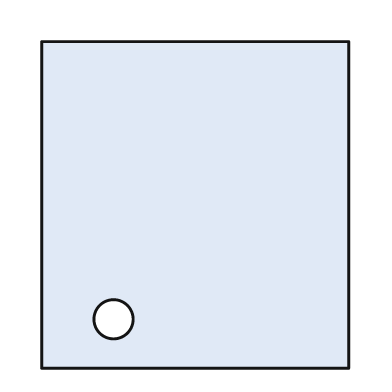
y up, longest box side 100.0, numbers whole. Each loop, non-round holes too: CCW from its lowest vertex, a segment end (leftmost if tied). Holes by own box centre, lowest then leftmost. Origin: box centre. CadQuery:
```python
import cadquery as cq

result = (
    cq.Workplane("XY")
    .moveTo(-47.0, -50.0)
    .lineTo(47.0, -50.0)
    .lineTo(47.0, 50.0)
    .lineTo(-47.0, 50.0)
    .close()
    .moveTo(-25.0, -35.0)
    .circle(6.0)
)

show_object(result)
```